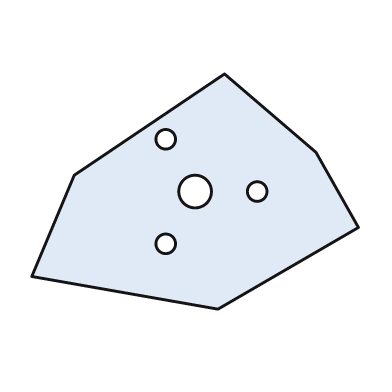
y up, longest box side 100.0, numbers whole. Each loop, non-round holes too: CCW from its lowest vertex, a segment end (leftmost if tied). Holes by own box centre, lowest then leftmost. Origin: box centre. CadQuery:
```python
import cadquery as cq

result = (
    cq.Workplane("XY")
    .moveTo(7.0, -36.0)
    .lineTo(50.0, -11.0)
    .lineTo(37.0, 12.0)
    .lineTo(9.0, 36.0)
    .lineTo(-37.0, 5.0)
    .lineTo(-50.0, -26.0)
    .close()
    .moveTo(-9.0, -16.0)
    .circle(3.0)
    .moveTo(0.0, 0.0)
    .circle(5.0)
    .moveTo(19.0, 0.0)
    .circle(3.0)
    .moveTo(-9.0, 16.0)
    .circle(3.0)
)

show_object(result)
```